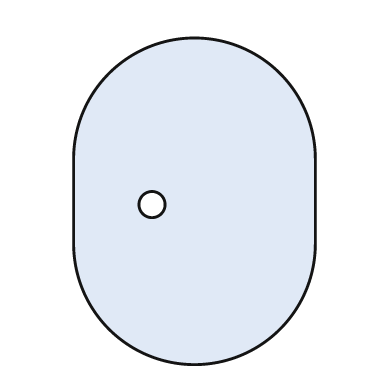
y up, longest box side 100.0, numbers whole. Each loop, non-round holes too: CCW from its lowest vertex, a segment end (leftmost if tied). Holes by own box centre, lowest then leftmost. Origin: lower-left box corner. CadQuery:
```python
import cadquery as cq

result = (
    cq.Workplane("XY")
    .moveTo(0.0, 37.0)
    .threePointArc((37.0, 0.0), (74.0, 37.0))
    .lineTo(74.0, 63.0)
    .threePointArc((37.0, 100.0), (0.0, 63.0))
    .close()
    .moveTo(24.0, 49.0)
    .circle(4.0)
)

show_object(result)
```